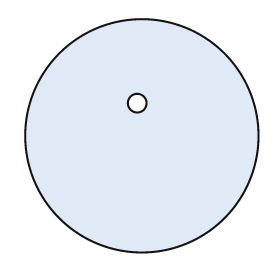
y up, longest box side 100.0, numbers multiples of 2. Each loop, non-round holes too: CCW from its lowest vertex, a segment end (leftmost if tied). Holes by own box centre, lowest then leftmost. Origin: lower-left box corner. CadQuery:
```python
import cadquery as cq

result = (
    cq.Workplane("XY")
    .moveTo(50.0, 50.0)
    .circle(50.0)
    .moveTo(48.0, 64.0)
    .circle(4.0)
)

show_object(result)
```